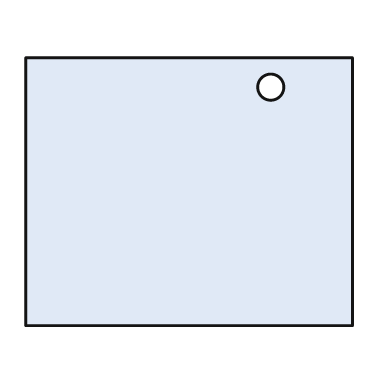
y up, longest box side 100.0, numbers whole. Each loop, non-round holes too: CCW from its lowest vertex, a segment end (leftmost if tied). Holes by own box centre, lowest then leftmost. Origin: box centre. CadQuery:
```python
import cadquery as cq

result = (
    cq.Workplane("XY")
    .moveTo(-50.0, -41.0)
    .lineTo(50.0, -41.0)
    .lineTo(50.0, 41.0)
    .lineTo(-50.0, 41.0)
    .close()
    .moveTo(25.0, 32.0)
    .circle(4.0)
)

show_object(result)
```